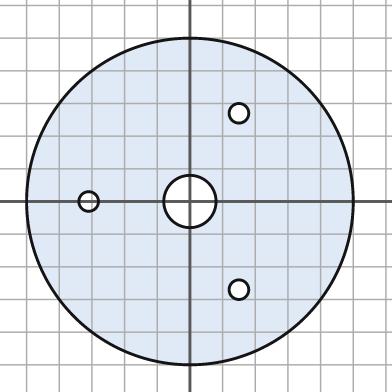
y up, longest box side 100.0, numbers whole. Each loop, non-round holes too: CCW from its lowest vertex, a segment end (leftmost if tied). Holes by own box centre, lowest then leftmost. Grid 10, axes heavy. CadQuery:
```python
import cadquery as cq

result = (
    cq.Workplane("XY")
    .moveTo(0.0, 0.0)
    .circle(50.0)
    .moveTo(15.0, -27.0)
    .circle(3.0)
    .moveTo(-31.0, 0.0)
    .circle(3.0)
    .moveTo(0.0, 0.0)
    .circle(8.0)
    .moveTo(15.0, 27.0)
    .circle(3.0)
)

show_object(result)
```